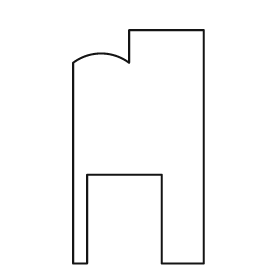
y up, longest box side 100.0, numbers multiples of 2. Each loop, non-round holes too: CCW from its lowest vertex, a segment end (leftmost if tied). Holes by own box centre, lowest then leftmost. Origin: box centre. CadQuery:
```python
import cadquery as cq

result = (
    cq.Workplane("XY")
    .moveTo(-28.0, -50.0)
    .lineTo(-22.0, -50.0)
    .lineTo(-22.0, -12.0)
    .lineTo(10.0, -12.0)
    .lineTo(10.0, -50.0)
    .lineTo(28.0, -50.0)
    .lineTo(28.0, 50.0)
    .lineTo(-4.0, 50.0)
    .lineTo(-4.0, 36.0)
    .threePointArc((-16.0, 40.0), (-28.0, 36.0))
    .close()
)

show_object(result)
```